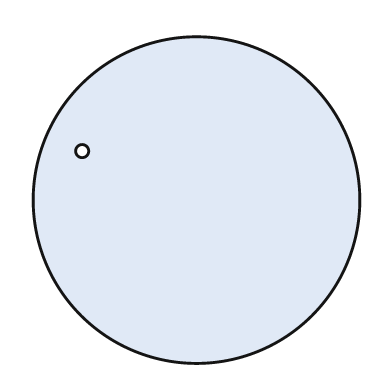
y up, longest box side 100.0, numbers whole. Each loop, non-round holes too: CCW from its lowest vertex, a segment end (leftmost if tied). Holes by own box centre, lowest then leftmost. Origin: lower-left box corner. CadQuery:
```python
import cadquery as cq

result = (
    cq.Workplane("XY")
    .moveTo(50.0, 50.0)
    .circle(50.0)
    .moveTo(15.0, 65.0)
    .circle(2.0)
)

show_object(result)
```